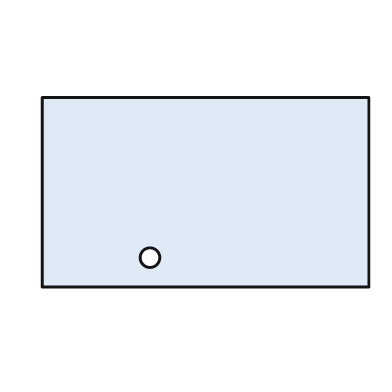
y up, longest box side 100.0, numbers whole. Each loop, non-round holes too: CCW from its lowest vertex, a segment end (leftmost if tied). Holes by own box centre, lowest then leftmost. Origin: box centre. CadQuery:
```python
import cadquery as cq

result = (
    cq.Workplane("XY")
    .moveTo(-50.0, -29.0)
    .lineTo(50.0, -29.0)
    .lineTo(50.0, 29.0)
    .lineTo(-50.0, 29.0)
    .close()
    .moveTo(-17.0, -20.0)
    .circle(3.0)
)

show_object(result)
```